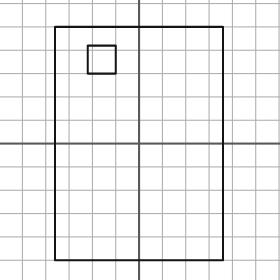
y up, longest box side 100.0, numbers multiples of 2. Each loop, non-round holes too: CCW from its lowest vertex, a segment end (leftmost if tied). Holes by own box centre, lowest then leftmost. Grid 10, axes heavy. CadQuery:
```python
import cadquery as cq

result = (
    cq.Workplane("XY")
    .moveTo(-36.0, -50.0)
    .lineTo(36.0, -50.0)
    .lineTo(36.0, 50.0)
    .lineTo(-36.0, 50.0)
    .close()
    .moveTo(-22.0, 30.0)
    .lineTo(-10.0, 30.0)
    .lineTo(-10.0, 42.0)
    .lineTo(-22.0, 42.0)
    .close()
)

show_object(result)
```